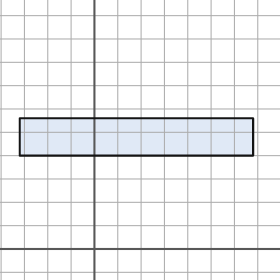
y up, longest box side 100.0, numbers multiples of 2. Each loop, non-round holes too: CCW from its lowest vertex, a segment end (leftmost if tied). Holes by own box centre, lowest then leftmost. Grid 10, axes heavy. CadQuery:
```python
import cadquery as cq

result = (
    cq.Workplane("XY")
    .moveTo(-32.0, 40.0)
    .lineTo(68.0, 40.0)
    .lineTo(68.0, 56.0)
    .lineTo(-32.0, 56.0)
    .close()
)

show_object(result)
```